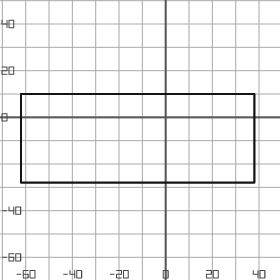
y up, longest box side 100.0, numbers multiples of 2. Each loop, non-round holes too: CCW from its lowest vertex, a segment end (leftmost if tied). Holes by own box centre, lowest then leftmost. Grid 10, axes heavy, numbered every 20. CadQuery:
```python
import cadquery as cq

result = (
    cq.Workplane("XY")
    .moveTo(-62.0, -28.0)
    .lineTo(38.0, -28.0)
    .lineTo(38.0, 10.0)
    .lineTo(-62.0, 10.0)
    .close()
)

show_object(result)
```